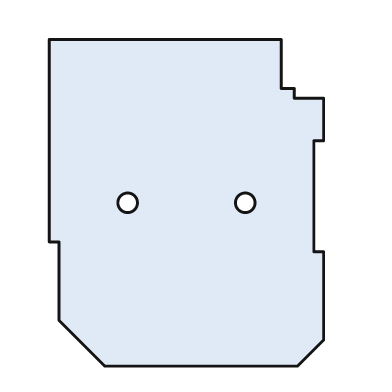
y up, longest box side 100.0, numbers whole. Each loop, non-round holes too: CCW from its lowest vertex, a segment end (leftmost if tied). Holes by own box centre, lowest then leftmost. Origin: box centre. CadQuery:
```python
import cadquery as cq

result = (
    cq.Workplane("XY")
    .moveTo(-25.0, -50.0)
    .lineTo(34.0, -50.0)
    .lineTo(42.0, -42.0)
    .lineTo(42.0, -15.0)
    .lineTo(39.0, -15.0)
    .lineTo(39.0, 19.0)
    .lineTo(42.0, 19.0)
    .lineTo(42.0, 32.0)
    .lineTo(33.0, 32.0)
    .lineTo(33.0, 35.0)
    .lineTo(29.0, 35.0)
    .lineTo(29.0, 50.0)
    .lineTo(-42.0, 50.0)
    .lineTo(-42.0, -12.0)
    .lineTo(-39.0, -12.0)
    .lineTo(-39.0, -36.0)
    .close()
    .moveTo(-18.0, 0.0)
    .circle(3.0)
    .moveTo(18.0, 0.0)
    .circle(3.0)
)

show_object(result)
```